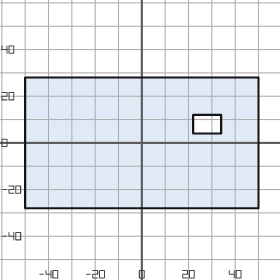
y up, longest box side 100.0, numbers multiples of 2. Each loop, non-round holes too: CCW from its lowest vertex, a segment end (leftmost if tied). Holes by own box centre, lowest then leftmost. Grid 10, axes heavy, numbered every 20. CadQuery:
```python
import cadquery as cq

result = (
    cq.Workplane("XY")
    .moveTo(-50.0, -28.0)
    .lineTo(50.0, -28.0)
    .lineTo(50.0, 28.0)
    .lineTo(-50.0, 28.0)
    .close()
    .moveTo(22.0, 4.0)
    .lineTo(34.0, 4.0)
    .lineTo(34.0, 12.0)
    .lineTo(22.0, 12.0)
    .close()
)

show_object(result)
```